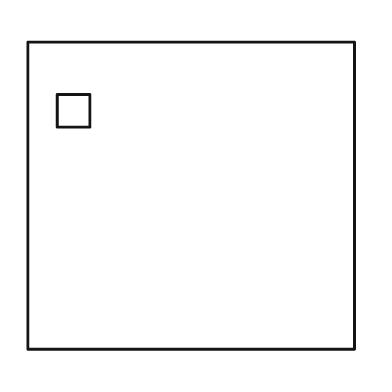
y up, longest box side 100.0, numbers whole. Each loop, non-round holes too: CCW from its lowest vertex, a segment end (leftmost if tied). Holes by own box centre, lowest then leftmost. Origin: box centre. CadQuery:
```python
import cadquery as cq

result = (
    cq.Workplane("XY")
    .moveTo(-50.0, -47.0)
    .lineTo(50.0, -47.0)
    .lineTo(50.0, 47.0)
    .lineTo(-50.0, 47.0)
    .close()
    .moveTo(-41.0, 21.0)
    .lineTo(-31.0, 21.0)
    .lineTo(-31.0, 31.0)
    .lineTo(-41.0, 31.0)
    .close()
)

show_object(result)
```